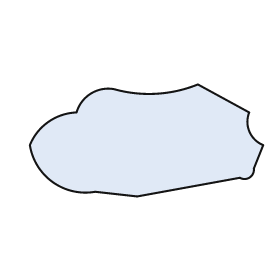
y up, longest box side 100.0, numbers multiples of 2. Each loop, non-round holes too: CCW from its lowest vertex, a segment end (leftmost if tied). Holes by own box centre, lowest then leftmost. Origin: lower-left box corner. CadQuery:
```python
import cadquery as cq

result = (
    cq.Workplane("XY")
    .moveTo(46.0, 0.0)
    .lineTo(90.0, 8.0)
    .threePointArc((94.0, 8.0), (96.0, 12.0))
    .lineTo(100.0, 22.0)
    .threePointArc((94.0, 28.0), (94.0, 36.0))
    .lineTo(72.0, 48.0)
    .threePointArc((54.0, 44.0), (36.0, 46.0))
    .threePointArc((26.0, 44.0), (20.0, 36.0))
    .threePointArc((8.0, 32.0), (0.0, 22.0))
    .threePointArc((10.0, 6.0), (28.0, 2.0))
    .close()
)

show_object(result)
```